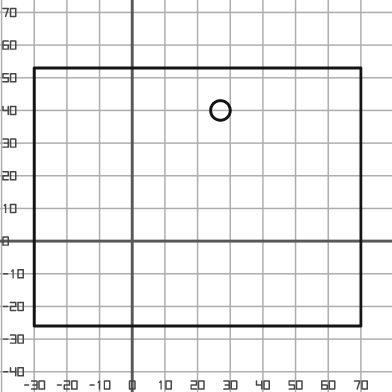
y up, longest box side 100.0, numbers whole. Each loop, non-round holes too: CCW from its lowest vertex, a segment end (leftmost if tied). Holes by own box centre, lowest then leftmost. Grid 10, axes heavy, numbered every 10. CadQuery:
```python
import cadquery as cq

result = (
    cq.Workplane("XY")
    .moveTo(-30.0, -26.0)
    .lineTo(70.0, -26.0)
    .lineTo(70.0, 53.0)
    .lineTo(-30.0, 53.0)
    .close()
    .moveTo(27.0, 40.0)
    .circle(3.0)
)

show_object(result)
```